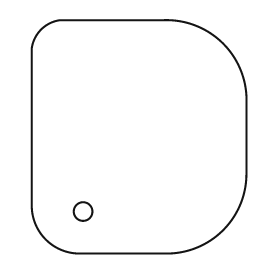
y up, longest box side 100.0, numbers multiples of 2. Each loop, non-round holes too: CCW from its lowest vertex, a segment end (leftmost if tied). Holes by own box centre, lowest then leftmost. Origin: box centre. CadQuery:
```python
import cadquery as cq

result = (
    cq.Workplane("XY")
    .moveTo(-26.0, -50.0)
    .lineTo(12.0, -50.0)
    .threePointArc((36.0, -40.0), (46.0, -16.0))
    .lineTo(46.0, 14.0)
    .threePointArc((36.0, 40.0), (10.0, 50.0))
    .lineTo(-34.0, 50.0)
    .threePointArc((-42.0, 46.0), (-46.0, 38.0))
    .lineTo(-46.0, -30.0)
    .threePointArc((-40.0, -44.0), (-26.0, -50.0))
    .close()
    .moveTo(-24.0, -32.0)
    .circle(4.0)
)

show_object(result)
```